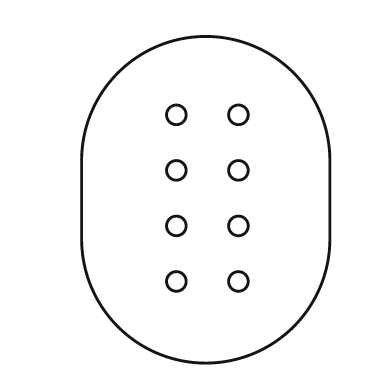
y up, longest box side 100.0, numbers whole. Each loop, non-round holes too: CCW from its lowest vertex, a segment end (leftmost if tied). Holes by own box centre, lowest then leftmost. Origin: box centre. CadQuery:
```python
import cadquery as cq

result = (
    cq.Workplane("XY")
    .moveTo(-38.0, -12.0)
    .threePointArc((0.0, -50.0), (38.0, -12.0))
    .lineTo(38.0, 12.0)
    .threePointArc((0.0, 50.0), (-38.0, 12.0))
    .close()
    .moveTo(-9.0, -25.0)
    .circle(3.0)
    .moveTo(10.0, -25.0)
    .circle(3.0)
    .moveTo(-9.0, -8.0)
    .circle(3.0)
    .moveTo(10.0, -8.0)
    .circle(3.0)
    .moveTo(-9.0, 9.0)
    .circle(3.0)
    .moveTo(10.0, 9.0)
    .circle(3.0)
    .moveTo(-9.0, 26.0)
    .circle(3.0)
    .moveTo(10.0, 26.0)
    .circle(3.0)
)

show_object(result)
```